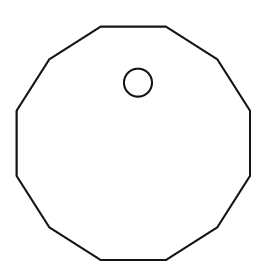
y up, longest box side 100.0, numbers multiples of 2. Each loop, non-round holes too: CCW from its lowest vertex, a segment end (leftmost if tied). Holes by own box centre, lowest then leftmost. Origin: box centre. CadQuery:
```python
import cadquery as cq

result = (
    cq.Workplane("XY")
    .moveTo(-14.0, -50.0)
    .lineTo(14.0, -50.0)
    .lineTo(36.0, -36.0)
    .lineTo(50.0, -14.0)
    .lineTo(50.0, 14.0)
    .lineTo(36.0, 36.0)
    .lineTo(14.0, 50.0)
    .lineTo(-14.0, 50.0)
    .lineTo(-36.0, 36.0)
    .lineTo(-50.0, 14.0)
    .lineTo(-50.0, -14.0)
    .lineTo(-36.0, -36.0)
    .close()
    .moveTo(2.0, 26.0)
    .circle(6.0)
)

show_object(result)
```